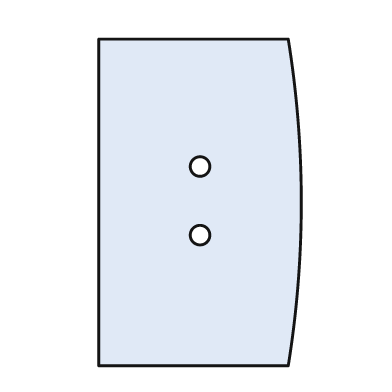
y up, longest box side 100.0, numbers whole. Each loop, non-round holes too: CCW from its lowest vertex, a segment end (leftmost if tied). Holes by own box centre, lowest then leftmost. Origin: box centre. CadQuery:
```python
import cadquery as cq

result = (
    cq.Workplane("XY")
    .moveTo(-31.0, -50.0)
    .lineTo(27.0, -50.0)
    .threePointArc((31.0, 0.0), (27.0, 50.0))
    .lineTo(-31.0, 50.0)
    .close()
    .moveTo(0.0, -10.0)
    .circle(3.0)
    .moveTo(0.0, 11.0)
    .circle(3.0)
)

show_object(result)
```